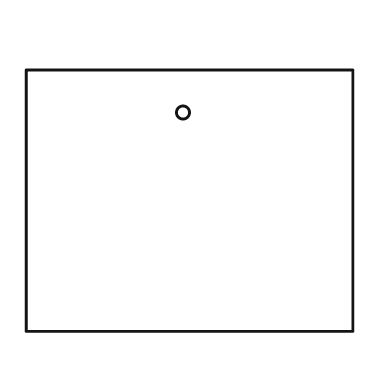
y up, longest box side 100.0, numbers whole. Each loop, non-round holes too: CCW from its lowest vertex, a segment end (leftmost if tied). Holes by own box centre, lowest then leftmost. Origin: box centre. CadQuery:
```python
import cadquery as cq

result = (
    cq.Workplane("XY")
    .moveTo(-50.0, -40.0)
    .lineTo(50.0, -40.0)
    .lineTo(50.0, 40.0)
    .lineTo(-50.0, 40.0)
    .close()
    .moveTo(-2.0, 27.0)
    .circle(2.0)
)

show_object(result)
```